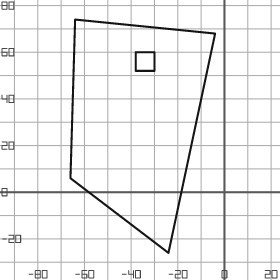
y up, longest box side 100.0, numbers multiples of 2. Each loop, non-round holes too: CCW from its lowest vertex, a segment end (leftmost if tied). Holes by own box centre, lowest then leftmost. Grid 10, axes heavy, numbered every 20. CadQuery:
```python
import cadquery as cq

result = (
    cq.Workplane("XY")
    .moveTo(-24.0, -26.0)
    .lineTo(-4.0, 68.0)
    .lineTo(-64.0, 74.0)
    .lineTo(-66.0, 6.0)
    .close()
    .moveTo(-38.0, 52.0)
    .lineTo(-30.0, 52.0)
    .lineTo(-30.0, 60.0)
    .lineTo(-38.0, 60.0)
    .close()
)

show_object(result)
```